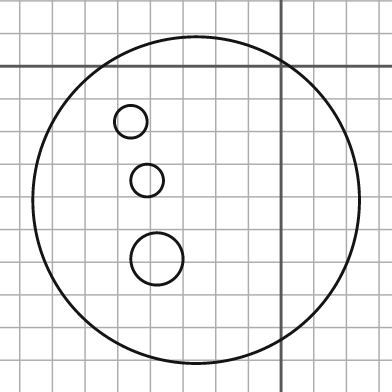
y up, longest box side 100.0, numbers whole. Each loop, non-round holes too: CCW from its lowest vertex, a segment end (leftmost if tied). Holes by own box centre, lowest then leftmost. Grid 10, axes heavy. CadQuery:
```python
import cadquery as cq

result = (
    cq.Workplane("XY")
    .moveTo(-26.0, -41.0)
    .circle(50.0)
    .moveTo(-38.0, -59.0)
    .circle(8.0)
    .moveTo(-41.0, -35.0)
    .circle(5.0)
    .moveTo(-46.0, -17.0)
    .circle(5.0)
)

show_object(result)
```